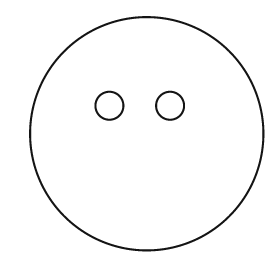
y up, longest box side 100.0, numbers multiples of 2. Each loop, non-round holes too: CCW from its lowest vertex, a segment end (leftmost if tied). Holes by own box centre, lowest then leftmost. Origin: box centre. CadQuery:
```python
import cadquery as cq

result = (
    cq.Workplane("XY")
    .moveTo(0.0, 0.0)
    .circle(50.0)
    .moveTo(-16.0, 12.0)
    .circle(6.0)
    .moveTo(10.0, 12.0)
    .circle(6.0)
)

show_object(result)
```